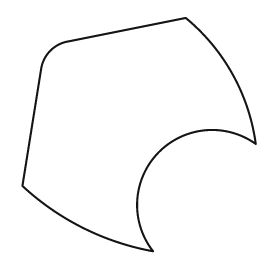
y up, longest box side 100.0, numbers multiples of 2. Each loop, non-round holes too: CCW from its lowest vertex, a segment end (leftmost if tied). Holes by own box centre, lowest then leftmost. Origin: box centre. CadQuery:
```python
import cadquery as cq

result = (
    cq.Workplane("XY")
    .moveTo(6.0, -50.0)
    .threePointArc((8.0, -8.0), (50.0, -4.0))
    .threePointArc((40.0, 26.0), (20.0, 50.0))
    .lineTo(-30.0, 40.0)
    .threePointArc((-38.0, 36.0), (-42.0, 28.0))
    .lineTo(-50.0, -22.0)
    .threePointArc((-24.0, -40.0), (6.0, -50.0))
    .close()
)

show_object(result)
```